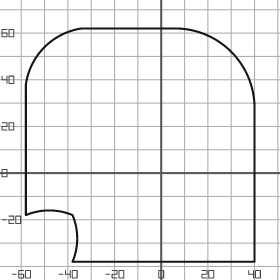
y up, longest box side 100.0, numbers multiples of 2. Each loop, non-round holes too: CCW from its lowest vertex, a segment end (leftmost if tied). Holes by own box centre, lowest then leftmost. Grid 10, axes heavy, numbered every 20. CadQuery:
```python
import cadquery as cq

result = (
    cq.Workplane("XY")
    .moveTo(-38.0, -38.0)
    .lineTo(40.0, -38.0)
    .lineTo(40.0, 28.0)
    .threePointArc((30.0, 52.0), (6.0, 62.0))
    .lineTo(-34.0, 62.0)
    .threePointArc((-50.0, 54.0), (-58.0, 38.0))
    .lineTo(-58.0, -18.0)
    .threePointArc((-48.0, -16.0), (-38.0, -18.0))
    .threePointArc((-36.0, -28.0), (-38.0, -38.0))
    .close()
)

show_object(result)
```